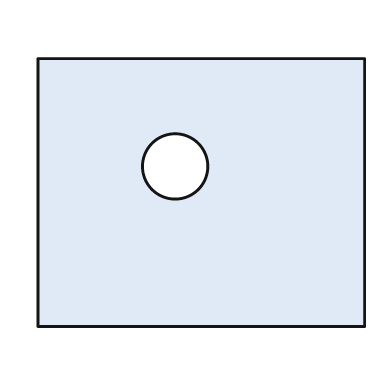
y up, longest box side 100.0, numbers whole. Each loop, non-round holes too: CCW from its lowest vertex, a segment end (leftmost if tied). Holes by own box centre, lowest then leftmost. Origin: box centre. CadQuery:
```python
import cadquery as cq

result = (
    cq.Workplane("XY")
    .moveTo(-50.0, -41.0)
    .lineTo(50.0, -41.0)
    .lineTo(50.0, 41.0)
    .lineTo(-50.0, 41.0)
    .close()
    .moveTo(-8.0, 8.0)
    .circle(10.0)
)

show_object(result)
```